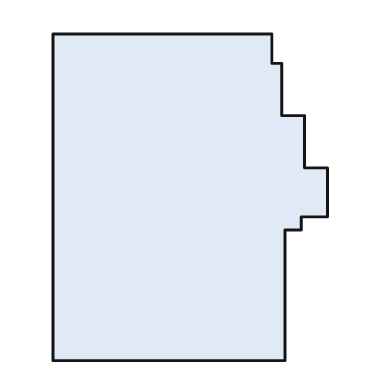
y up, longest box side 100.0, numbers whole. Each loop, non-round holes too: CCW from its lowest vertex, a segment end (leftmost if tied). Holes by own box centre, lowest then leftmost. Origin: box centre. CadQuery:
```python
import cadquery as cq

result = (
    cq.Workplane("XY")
    .moveTo(-42.0, -50.0)
    .lineTo(29.0, -50.0)
    .lineTo(29.0, -10.0)
    .lineTo(34.0, -10.0)
    .lineTo(34.0, -6.0)
    .lineTo(42.0, -6.0)
    .lineTo(42.0, 9.0)
    .lineTo(35.0, 9.0)
    .lineTo(35.0, 25.0)
    .lineTo(28.0, 25.0)
    .lineTo(28.0, 41.0)
    .lineTo(25.0, 41.0)
    .lineTo(25.0, 50.0)
    .lineTo(-42.0, 50.0)
    .close()
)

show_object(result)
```